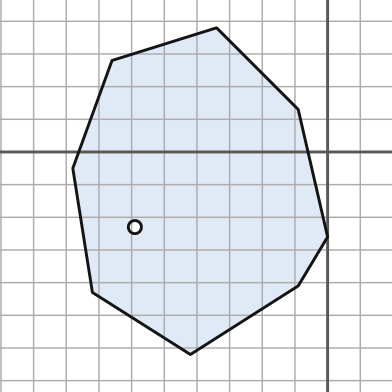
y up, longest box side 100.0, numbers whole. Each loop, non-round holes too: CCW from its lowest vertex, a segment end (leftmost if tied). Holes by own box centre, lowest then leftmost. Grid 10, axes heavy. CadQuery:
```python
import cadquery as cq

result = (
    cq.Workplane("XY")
    .moveTo(-42.0, -62.0)
    .lineTo(-9.0, -41.0)
    .lineTo(0.0, -26.0)
    .lineTo(-9.0, 13.0)
    .lineTo(-34.0, 38.0)
    .lineTo(-66.0, 28.0)
    .lineTo(-78.0, -5.0)
    .lineTo(-72.0, -43.0)
    .close()
    .moveTo(-59.0, -23.0)
    .circle(2.0)
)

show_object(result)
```